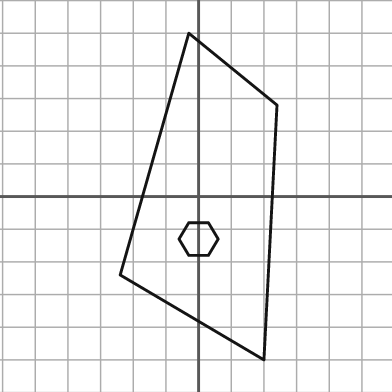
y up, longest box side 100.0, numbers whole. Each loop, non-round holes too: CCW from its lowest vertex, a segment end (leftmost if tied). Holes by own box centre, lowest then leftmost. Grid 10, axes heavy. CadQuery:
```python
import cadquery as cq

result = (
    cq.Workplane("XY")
    .moveTo(20.0, -50.0)
    .lineTo(24.0, 28.0)
    .lineTo(-3.0, 50.0)
    .lineTo(-24.0, -24.0)
    .close()
    .moveTo(-3.0, -18.0)
    .lineTo(3.0, -18.0)
    .lineTo(6.0, -13.0)
    .lineTo(3.0, -8.0)
    .lineTo(-3.0, -8.0)
    .lineTo(-6.0, -13.0)
    .close()
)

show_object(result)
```